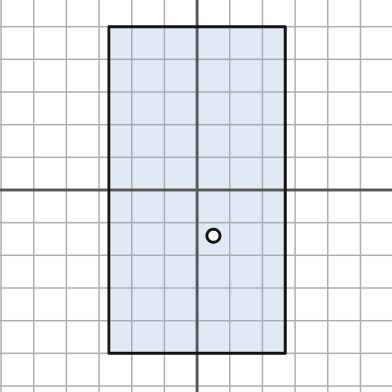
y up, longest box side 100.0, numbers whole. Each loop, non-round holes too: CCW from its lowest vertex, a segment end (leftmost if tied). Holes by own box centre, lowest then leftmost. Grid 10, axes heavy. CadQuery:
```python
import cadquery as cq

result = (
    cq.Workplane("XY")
    .moveTo(-27.0, -50.0)
    .lineTo(27.0, -50.0)
    .lineTo(27.0, 50.0)
    .lineTo(-27.0, 50.0)
    .close()
    .moveTo(5.0, -14.0)
    .circle(2.0)
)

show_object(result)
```